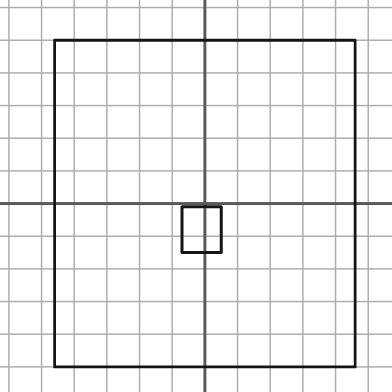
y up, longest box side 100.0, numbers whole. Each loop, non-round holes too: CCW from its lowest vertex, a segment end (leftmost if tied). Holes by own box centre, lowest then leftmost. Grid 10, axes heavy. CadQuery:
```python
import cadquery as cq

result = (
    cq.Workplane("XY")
    .moveTo(-46.0, -50.0)
    .lineTo(46.0, -50.0)
    .lineTo(46.0, 50.0)
    .lineTo(-46.0, 50.0)
    .close()
    .moveTo(-7.0, -15.0)
    .lineTo(5.0, -15.0)
    .lineTo(5.0, -1.0)
    .lineTo(-7.0, -1.0)
    .close()
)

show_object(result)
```